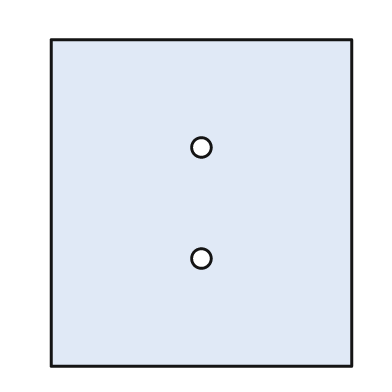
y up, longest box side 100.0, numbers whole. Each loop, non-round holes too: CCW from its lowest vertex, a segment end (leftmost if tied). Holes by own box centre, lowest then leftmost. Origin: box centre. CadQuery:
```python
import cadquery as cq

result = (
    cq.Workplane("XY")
    .moveTo(-46.0, -50.0)
    .lineTo(46.0, -50.0)
    .lineTo(46.0, 50.0)
    .lineTo(-46.0, 50.0)
    .close()
    .moveTo(0.0, -17.0)
    .circle(3.0)
    .moveTo(0.0, 17.0)
    .circle(3.0)
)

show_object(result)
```